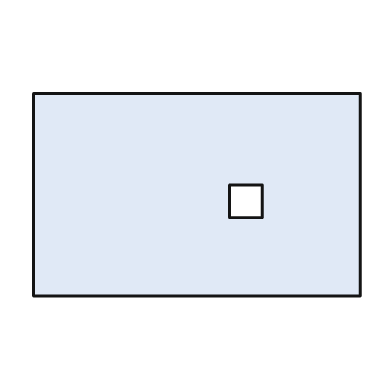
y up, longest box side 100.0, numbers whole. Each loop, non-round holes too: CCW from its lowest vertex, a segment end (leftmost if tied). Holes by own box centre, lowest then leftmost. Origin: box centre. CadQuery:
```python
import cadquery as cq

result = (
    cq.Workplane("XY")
    .moveTo(-50.0, -31.0)
    .lineTo(50.0, -31.0)
    .lineTo(50.0, 31.0)
    .lineTo(-50.0, 31.0)
    .close()
    .moveTo(10.0, -7.0)
    .lineTo(20.0, -7.0)
    .lineTo(20.0, 3.0)
    .lineTo(10.0, 3.0)
    .close()
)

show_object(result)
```